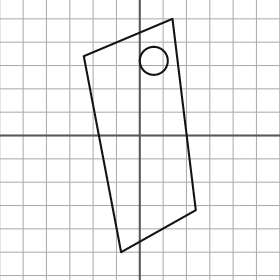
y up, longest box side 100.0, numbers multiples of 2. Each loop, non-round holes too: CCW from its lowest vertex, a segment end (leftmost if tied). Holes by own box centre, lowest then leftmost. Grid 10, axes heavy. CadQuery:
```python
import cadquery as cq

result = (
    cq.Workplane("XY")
    .moveTo(-8.0, -50.0)
    .lineTo(24.0, -32.0)
    .lineTo(14.0, 50.0)
    .lineTo(-24.0, 34.0)
    .close()
    .moveTo(6.0, 32.0)
    .circle(6.0)
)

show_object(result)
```